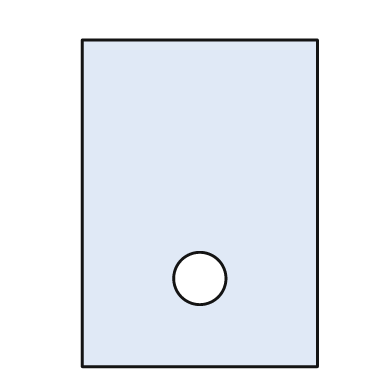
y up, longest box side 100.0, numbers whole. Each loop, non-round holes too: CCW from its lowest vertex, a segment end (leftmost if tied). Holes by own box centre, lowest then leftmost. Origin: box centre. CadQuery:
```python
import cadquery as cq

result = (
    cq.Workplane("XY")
    .moveTo(-36.0, -50.0)
    .lineTo(36.0, -50.0)
    .lineTo(36.0, 50.0)
    .lineTo(-36.0, 50.0)
    .close()
    .moveTo(0.0, -23.0)
    .circle(8.0)
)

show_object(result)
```